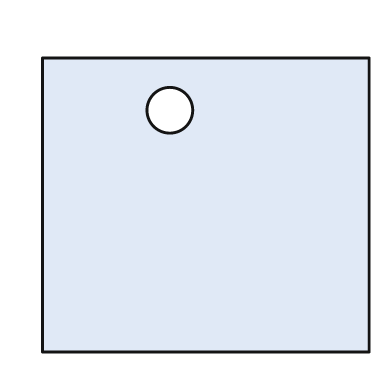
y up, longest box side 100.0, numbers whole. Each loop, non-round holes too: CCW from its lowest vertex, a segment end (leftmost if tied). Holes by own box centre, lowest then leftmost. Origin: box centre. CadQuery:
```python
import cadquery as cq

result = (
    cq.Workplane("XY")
    .moveTo(-50.0, -45.0)
    .lineTo(50.0, -45.0)
    .lineTo(50.0, 45.0)
    .lineTo(-50.0, 45.0)
    .close()
    .moveTo(-11.0, 29.0)
    .circle(7.0)
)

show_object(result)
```